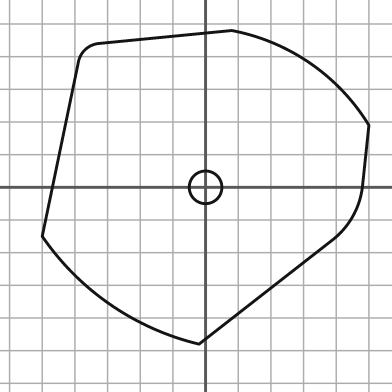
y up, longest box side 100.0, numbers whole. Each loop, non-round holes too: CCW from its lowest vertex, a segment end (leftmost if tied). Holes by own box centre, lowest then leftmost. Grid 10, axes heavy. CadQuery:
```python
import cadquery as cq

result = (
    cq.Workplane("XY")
    .moveTo(-2.0, -48.0)
    .lineTo(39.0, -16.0)
    .threePointArc((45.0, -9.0), (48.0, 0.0))
    .lineTo(50.0, 19.0)
    .threePointArc((32.0, 38.0), (8.0, 48.0))
    .lineTo(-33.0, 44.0)
    .threePointArc((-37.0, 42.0), (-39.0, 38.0))
    .lineTo(-50.0, -15.0)
    .threePointArc((-29.0, -36.0), (-2.0, -48.0))
    .close()
    .moveTo(0.0, 0.0)
    .circle(5.0)
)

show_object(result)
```